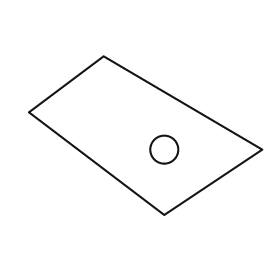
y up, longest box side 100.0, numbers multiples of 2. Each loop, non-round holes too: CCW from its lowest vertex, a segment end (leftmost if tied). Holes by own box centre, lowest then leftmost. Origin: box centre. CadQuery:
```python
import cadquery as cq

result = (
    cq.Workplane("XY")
    .moveTo(8.0, -34.0)
    .lineTo(50.0, -6.0)
    .lineTo(-18.0, 34.0)
    .lineTo(-50.0, 10.0)
    .close()
    .moveTo(8.0, -6.0)
    .circle(6.0)
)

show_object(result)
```